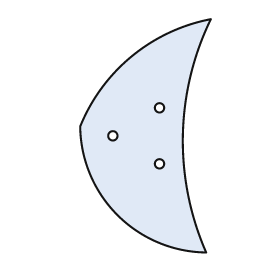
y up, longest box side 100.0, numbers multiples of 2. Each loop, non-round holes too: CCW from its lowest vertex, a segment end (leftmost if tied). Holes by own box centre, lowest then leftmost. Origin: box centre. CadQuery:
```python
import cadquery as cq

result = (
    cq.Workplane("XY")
    .moveTo(26.0, -50.0)
    .threePointArc((16.0, 0.0), (28.0, 50.0))
    .threePointArc((-6.0, 34.0), (-28.0, 4.0))
    .threePointArc((-12.0, -34.0), (26.0, -50.0))
    .close()
    .moveTo(6.0, -12.0)
    .circle(2.0)
    .moveTo(-14.0, 0.0)
    .circle(2.0)
    .moveTo(6.0, 12.0)
    .circle(2.0)
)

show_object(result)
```